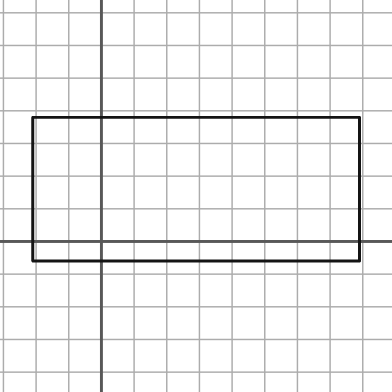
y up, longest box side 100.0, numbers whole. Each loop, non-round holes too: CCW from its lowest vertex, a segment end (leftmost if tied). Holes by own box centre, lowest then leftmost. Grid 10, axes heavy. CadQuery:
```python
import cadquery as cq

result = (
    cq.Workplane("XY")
    .moveTo(-21.0, -6.0)
    .lineTo(79.0, -6.0)
    .lineTo(79.0, 38.0)
    .lineTo(-21.0, 38.0)
    .close()
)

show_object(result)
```